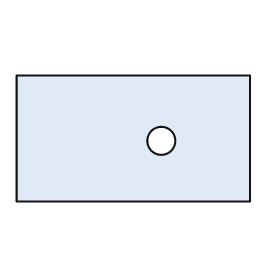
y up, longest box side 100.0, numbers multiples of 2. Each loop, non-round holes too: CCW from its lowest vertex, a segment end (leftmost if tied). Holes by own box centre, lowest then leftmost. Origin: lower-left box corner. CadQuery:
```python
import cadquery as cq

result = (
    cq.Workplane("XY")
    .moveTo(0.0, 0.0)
    .lineTo(100.0, 0.0)
    .lineTo(100.0, 54.0)
    .lineTo(0.0, 54.0)
    .close()
    .moveTo(62.0, 26.0)
    .circle(6.0)
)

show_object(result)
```